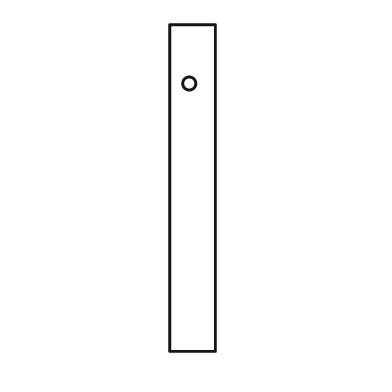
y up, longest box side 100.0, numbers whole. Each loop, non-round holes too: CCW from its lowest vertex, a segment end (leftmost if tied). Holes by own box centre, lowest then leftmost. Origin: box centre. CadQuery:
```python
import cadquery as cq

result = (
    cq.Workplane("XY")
    .moveTo(-7.0, -50.0)
    .lineTo(7.0, -50.0)
    .lineTo(7.0, 50.0)
    .lineTo(-7.0, 50.0)
    .close()
    .moveTo(-1.0, 32.0)
    .circle(2.0)
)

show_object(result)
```